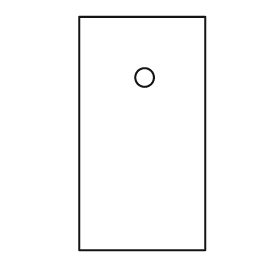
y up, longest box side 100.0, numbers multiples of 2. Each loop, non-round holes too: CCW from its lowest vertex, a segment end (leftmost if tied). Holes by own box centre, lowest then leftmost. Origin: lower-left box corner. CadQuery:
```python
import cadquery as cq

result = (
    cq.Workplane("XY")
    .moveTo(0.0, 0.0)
    .lineTo(54.0, 0.0)
    .lineTo(54.0, 100.0)
    .lineTo(0.0, 100.0)
    .close()
    .moveTo(28.0, 74.0)
    .circle(4.0)
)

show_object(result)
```